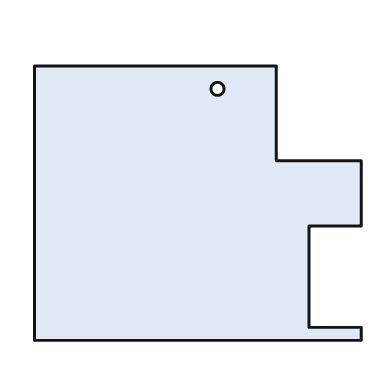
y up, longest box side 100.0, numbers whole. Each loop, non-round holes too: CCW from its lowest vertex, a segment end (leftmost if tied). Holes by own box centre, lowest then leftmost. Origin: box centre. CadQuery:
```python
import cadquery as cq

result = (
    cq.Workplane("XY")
    .moveTo(-50.0, -42.0)
    .lineTo(50.0, -42.0)
    .lineTo(50.0, -38.0)
    .lineTo(34.0, -38.0)
    .lineTo(34.0, -7.0)
    .lineTo(50.0, -7.0)
    .lineTo(50.0, 13.0)
    .lineTo(24.0, 13.0)
    .lineTo(24.0, 42.0)
    .lineTo(-50.0, 42.0)
    .close()
    .moveTo(6.0, 35.0)
    .circle(2.0)
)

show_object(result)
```